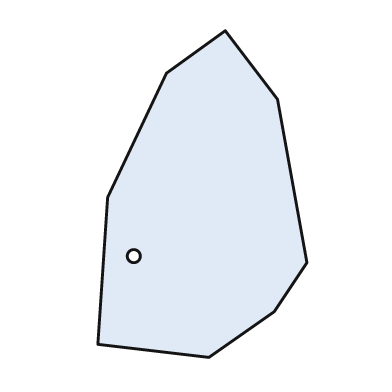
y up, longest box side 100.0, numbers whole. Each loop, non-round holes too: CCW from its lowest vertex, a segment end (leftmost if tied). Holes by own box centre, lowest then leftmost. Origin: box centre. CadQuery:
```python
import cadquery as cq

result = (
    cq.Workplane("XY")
    .moveTo(2.0, -50.0)
    .lineTo(22.0, -36.0)
    .lineTo(32.0, -21.0)
    .lineTo(23.0, 29.0)
    .lineTo(7.0, 50.0)
    .lineTo(-11.0, 37.0)
    .lineTo(-29.0, -1.0)
    .lineTo(-32.0, -46.0)
    .close()
    .moveTo(-21.0, -19.0)
    .circle(2.0)
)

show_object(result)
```